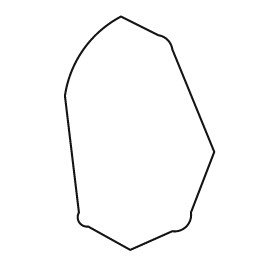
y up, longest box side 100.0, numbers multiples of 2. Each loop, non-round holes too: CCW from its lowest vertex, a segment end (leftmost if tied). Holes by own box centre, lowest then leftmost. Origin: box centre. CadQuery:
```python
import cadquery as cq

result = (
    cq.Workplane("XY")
    .moveTo(-4.0, -50.0)
    .lineTo(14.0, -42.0)
    .threePointArc((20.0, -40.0), (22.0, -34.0))
    .lineTo(32.0, -8.0)
    .lineTo(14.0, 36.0)
    .threePointArc((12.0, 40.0), (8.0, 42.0))
    .lineTo(-8.0, 50.0)
    .threePointArc((-24.0, 36.0), (-32.0, 16.0))
    .lineTo(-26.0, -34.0)
    .threePointArc((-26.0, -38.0), (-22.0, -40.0))
    .close()
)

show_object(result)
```